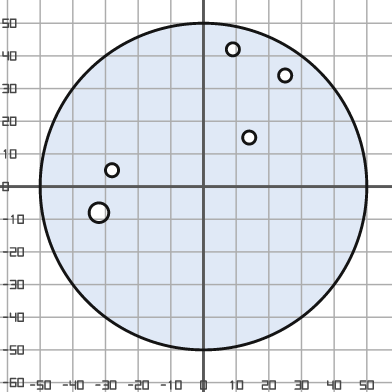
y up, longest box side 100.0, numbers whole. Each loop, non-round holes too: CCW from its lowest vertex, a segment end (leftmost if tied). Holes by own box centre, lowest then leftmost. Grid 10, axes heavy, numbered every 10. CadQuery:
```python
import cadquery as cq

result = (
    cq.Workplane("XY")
    .moveTo(0.0, 0.0)
    .circle(50.0)
    .moveTo(-32.0, -8.0)
    .circle(3.0)
    .moveTo(-28.0, 5.0)
    .circle(2.0)
    .moveTo(14.0, 15.0)
    .circle(2.0)
    .moveTo(25.0, 34.0)
    .circle(2.0)
    .moveTo(9.0, 42.0)
    .circle(2.0)
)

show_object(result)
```